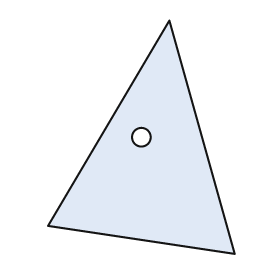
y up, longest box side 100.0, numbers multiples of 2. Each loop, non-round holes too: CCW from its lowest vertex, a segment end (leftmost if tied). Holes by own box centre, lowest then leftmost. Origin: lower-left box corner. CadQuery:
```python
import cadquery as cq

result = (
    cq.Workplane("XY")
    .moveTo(80.0, 0.0)
    .lineTo(52.0, 100.0)
    .lineTo(0.0, 12.0)
    .close()
    .moveTo(40.0, 50.0)
    .circle(4.0)
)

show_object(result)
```